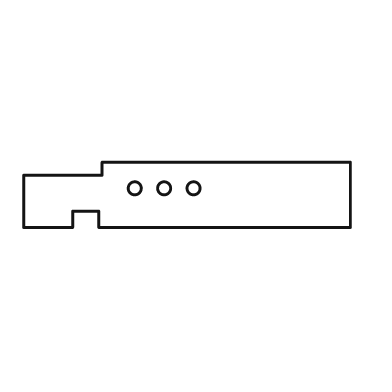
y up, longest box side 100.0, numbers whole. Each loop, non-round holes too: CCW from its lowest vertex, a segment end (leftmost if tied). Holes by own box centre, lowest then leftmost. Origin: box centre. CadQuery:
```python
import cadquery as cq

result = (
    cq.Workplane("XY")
    .moveTo(-50.0, -10.0)
    .lineTo(-35.0, -10.0)
    .lineTo(-35.0, -5.0)
    .lineTo(-27.0, -5.0)
    .lineTo(-27.0, -10.0)
    .lineTo(50.0, -10.0)
    .lineTo(50.0, 10.0)
    .lineTo(-26.0, 10.0)
    .lineTo(-26.0, 6.0)
    .lineTo(-50.0, 6.0)
    .close()
    .moveTo(-16.0, 2.0)
    .circle(2.0)
    .moveTo(-7.0, 2.0)
    .circle(2.0)
    .moveTo(2.0, 2.0)
    .circle(2.0)
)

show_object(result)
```